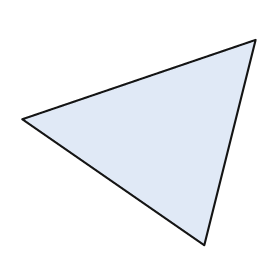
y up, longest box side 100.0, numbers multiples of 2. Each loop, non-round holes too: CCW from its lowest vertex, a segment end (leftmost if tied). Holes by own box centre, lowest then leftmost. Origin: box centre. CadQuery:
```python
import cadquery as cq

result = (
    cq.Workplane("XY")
    .moveTo(28.0, -44.0)
    .lineTo(50.0, 44.0)
    .lineTo(-50.0, 10.0)
    .close()
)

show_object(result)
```